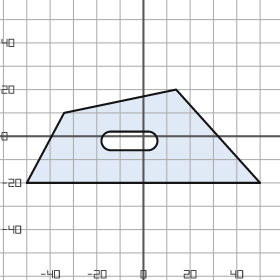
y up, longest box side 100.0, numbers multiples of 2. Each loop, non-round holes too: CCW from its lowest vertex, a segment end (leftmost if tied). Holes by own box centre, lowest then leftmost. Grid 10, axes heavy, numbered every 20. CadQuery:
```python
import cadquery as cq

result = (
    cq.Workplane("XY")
    .moveTo(-50.0, -20.0)
    .lineTo(50.0, -20.0)
    .lineTo(14.0, 20.0)
    .lineTo(-34.0, 10.0)
    .close()
    .moveTo(-14.0, -6.0)
    .lineTo(2.0, -6.0)
    .threePointArc((6.0, -2.0), (2.0, 2.0))
    .lineTo(-14.0, 2.0)
    .threePointArc((-18.0, -2.0), (-14.0, -6.0))
    .close()
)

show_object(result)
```